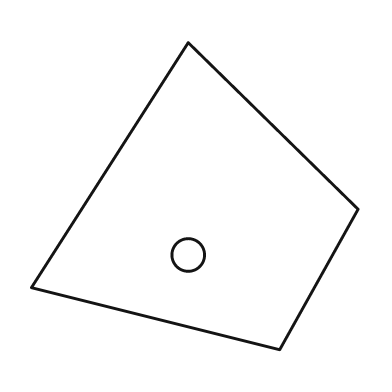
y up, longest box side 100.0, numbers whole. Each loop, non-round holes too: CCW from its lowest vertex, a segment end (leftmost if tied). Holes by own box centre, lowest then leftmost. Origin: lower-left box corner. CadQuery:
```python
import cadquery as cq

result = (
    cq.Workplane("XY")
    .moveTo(76.0, 0.0)
    .lineTo(100.0, 43.0)
    .lineTo(48.0, 94.0)
    .lineTo(0.0, 19.0)
    .close()
    .moveTo(48.0, 29.0)
    .circle(5.0)
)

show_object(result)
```